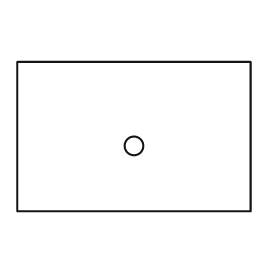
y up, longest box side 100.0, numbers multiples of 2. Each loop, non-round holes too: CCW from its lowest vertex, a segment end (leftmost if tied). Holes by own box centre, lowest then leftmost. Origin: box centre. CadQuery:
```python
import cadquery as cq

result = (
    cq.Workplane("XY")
    .moveTo(-50.0, -32.0)
    .lineTo(50.0, -32.0)
    .lineTo(50.0, 32.0)
    .lineTo(-50.0, 32.0)
    .close()
    .moveTo(0.0, -4.0)
    .circle(4.0)
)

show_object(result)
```